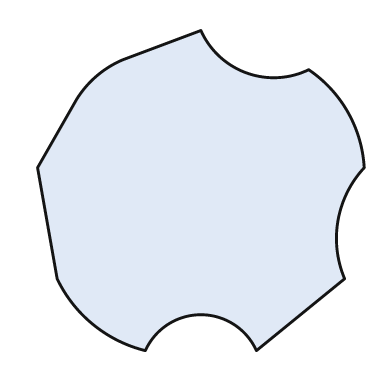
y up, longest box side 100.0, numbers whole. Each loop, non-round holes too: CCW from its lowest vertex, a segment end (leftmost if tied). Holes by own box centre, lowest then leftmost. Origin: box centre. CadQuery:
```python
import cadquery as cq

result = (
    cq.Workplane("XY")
    .moveTo(-17.0, -49.0)
    .threePointArc((0.0, -38.0), (17.0, -49.0))
    .lineTo(44.0, -27.0)
    .threePointArc((42.0, -9.0), (50.0, 7.0))
    .threePointArc((45.0, 24.0), (33.0, 37.0))
    .threePointArc((14.0, 36.0), (0.0, 49.0))
    .lineTo(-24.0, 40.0)
    .threePointArc((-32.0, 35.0), (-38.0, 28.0))
    .lineTo(-50.0, 7.0)
    .lineTo(-44.0, -27.0)
    .threePointArc((-33.0, -41.0), (-17.0, -49.0))
    .close()
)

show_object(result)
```